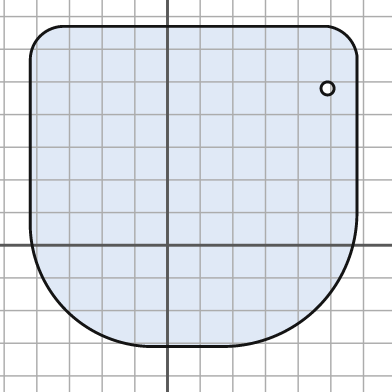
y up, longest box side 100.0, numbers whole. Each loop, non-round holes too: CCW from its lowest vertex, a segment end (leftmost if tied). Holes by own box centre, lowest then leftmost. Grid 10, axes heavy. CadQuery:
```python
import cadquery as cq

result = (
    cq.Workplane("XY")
    .moveTo(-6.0, -31.0)
    .lineTo(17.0, -31.0)
    .threePointArc((46.0, -19.0), (58.0, 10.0))
    .lineTo(58.0, 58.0)
    .threePointArc((55.0, 64.0), (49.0, 67.0))
    .lineTo(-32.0, 67.0)
    .threePointArc((-39.0, 64.0), (-42.0, 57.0))
    .lineTo(-42.0, 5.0)
    .threePointArc((-31.0, -20.0), (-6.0, -31.0))
    .close()
    .moveTo(49.0, 48.0)
    .circle(2.0)
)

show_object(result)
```